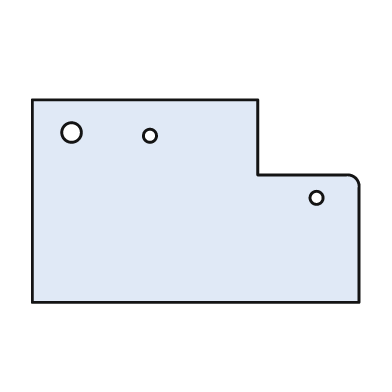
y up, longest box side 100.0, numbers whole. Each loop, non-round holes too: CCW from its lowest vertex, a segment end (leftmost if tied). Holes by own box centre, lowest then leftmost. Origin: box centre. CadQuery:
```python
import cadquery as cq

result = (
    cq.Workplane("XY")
    .moveTo(-50.0, -31.0)
    .lineTo(50.0, -31.0)
    .lineTo(50.0, 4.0)
    .threePointArc((49.0, 7.0), (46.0, 8.0))
    .lineTo(19.0, 8.0)
    .lineTo(19.0, 31.0)
    .lineTo(-50.0, 31.0)
    .close()
    .moveTo(37.0, 1.0)
    .circle(2.0)
    .moveTo(-14.0, 20.0)
    .circle(2.0)
    .moveTo(-38.0, 21.0)
    .circle(3.0)
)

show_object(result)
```